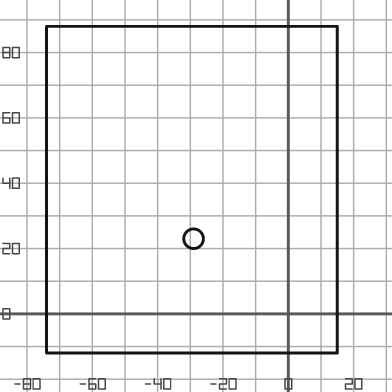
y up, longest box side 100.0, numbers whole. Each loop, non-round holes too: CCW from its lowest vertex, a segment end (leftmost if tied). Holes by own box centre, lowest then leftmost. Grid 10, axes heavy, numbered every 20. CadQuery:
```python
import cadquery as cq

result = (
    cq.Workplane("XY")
    .moveTo(-74.0, -12.0)
    .lineTo(15.0, -12.0)
    .lineTo(15.0, 88.0)
    .lineTo(-74.0, 88.0)
    .close()
    .moveTo(-29.0, 23.0)
    .circle(3.0)
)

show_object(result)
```